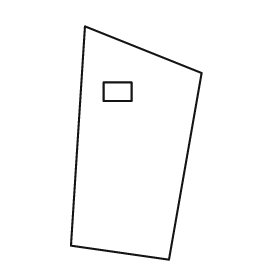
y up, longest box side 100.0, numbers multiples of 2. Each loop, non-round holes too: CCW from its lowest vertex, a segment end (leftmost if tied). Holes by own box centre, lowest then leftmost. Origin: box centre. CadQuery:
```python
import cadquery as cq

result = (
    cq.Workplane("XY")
    .moveTo(14.0, -50.0)
    .lineTo(28.0, 30.0)
    .lineTo(-22.0, 50.0)
    .lineTo(-28.0, -44.0)
    .close()
    .moveTo(-14.0, 18.0)
    .lineTo(-2.0, 18.0)
    .lineTo(-2.0, 26.0)
    .lineTo(-14.0, 26.0)
    .close()
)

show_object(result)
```